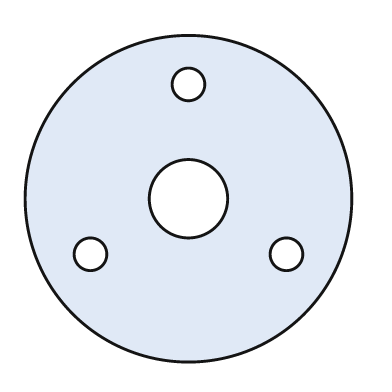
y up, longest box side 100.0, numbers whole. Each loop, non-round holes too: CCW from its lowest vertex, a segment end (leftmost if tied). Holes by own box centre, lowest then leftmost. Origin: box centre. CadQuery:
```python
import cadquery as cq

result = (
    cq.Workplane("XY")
    .moveTo(0.0, 0.0)
    .circle(50.0)
    .moveTo(-30.0, -17.0)
    .circle(5.0)
    .moveTo(30.0, -17.0)
    .circle(5.0)
    .moveTo(0.0, 0.0)
    .circle(12.0)
    .moveTo(0.0, 35.0)
    .circle(5.0)
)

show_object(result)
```